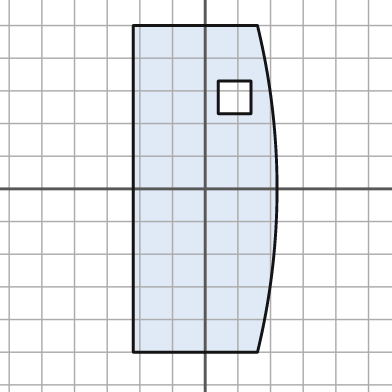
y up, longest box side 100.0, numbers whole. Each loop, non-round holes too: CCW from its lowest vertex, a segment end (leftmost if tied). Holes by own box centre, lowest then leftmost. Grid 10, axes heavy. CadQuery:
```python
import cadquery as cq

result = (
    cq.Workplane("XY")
    .moveTo(-22.0, -50.0)
    .lineTo(16.0, -50.0)
    .threePointArc((22.0, 0.0), (16.0, 50.0))
    .lineTo(-22.0, 50.0)
    .close()
    .moveTo(4.0, 23.0)
    .lineTo(14.0, 23.0)
    .lineTo(14.0, 33.0)
    .lineTo(4.0, 33.0)
    .close()
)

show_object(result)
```